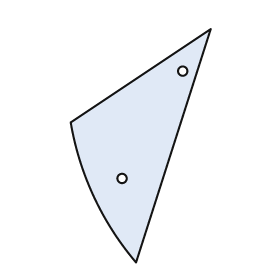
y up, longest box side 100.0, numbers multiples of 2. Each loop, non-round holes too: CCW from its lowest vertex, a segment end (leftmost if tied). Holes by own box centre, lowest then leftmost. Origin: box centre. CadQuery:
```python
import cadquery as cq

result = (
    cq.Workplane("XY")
    .moveTo(-2.0, -50.0)
    .lineTo(30.0, 50.0)
    .lineTo(-30.0, 10.0)
    .threePointArc((-20.0, -22.0), (-2.0, -50.0))
    .close()
    .moveTo(-8.0, -14.0)
    .circle(2.0)
    .moveTo(18.0, 32.0)
    .circle(2.0)
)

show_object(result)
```